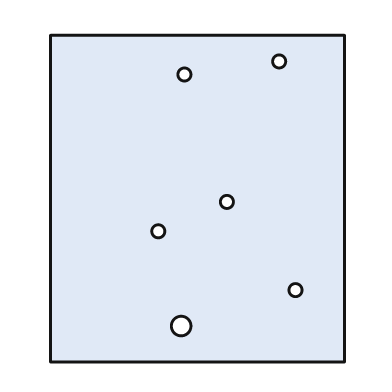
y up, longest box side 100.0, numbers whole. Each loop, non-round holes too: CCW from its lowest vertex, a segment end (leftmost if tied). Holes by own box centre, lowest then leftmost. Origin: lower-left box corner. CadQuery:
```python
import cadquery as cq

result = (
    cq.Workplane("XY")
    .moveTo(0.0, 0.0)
    .lineTo(90.0, 0.0)
    .lineTo(90.0, 100.0)
    .lineTo(0.0, 100.0)
    .close()
    .moveTo(40.0, 11.0)
    .circle(3.0)
    .moveTo(75.0, 22.0)
    .circle(2.0)
    .moveTo(33.0, 40.0)
    .circle(2.0)
    .moveTo(54.0, 49.0)
    .circle(2.0)
    .moveTo(41.0, 88.0)
    .circle(2.0)
    .moveTo(70.0, 92.0)
    .circle(2.0)
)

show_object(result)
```